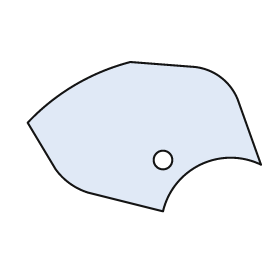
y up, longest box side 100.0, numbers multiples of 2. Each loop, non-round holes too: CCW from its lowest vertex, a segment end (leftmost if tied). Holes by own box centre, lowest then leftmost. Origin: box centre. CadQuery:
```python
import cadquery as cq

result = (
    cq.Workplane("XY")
    .moveTo(8.0, -32.0)
    .threePointArc((24.0, -12.0), (50.0, -12.0))
    .lineTo(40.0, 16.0)
    .threePointArc((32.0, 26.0), (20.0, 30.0))
    .lineTo(-6.0, 32.0)
    .threePointArc((-30.0, 22.0), (-50.0, 6.0))
    .lineTo(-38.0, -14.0)
    .threePointArc((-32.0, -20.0), (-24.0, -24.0))
    .close()
    .moveTo(8.0, -10.0)
    .circle(4.0)
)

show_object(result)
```